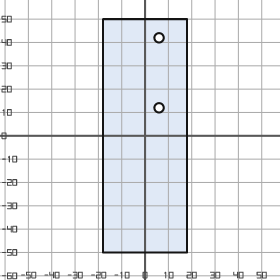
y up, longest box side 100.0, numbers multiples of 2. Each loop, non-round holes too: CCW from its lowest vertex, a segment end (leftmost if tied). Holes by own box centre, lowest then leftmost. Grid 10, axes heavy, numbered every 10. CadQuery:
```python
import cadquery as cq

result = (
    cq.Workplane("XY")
    .moveTo(-18.0, -50.0)
    .lineTo(18.0, -50.0)
    .lineTo(18.0, 50.0)
    .lineTo(-18.0, 50.0)
    .close()
    .moveTo(6.0, 12.0)
    .circle(2.0)
    .moveTo(6.0, 42.0)
    .circle(2.0)
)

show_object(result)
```